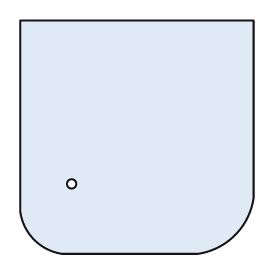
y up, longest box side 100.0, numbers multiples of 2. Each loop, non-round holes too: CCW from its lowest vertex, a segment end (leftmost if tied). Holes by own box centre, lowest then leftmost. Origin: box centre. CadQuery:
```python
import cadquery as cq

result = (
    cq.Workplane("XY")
    .moveTo(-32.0, -50.0)
    .lineTo(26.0, -50.0)
    .threePointArc((42.0, -42.0), (50.0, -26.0))
    .lineTo(50.0, 50.0)
    .lineTo(-50.0, 50.0)
    .lineTo(-50.0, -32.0)
    .threePointArc((-44.0, -44.0), (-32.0, -50.0))
    .close()
    .moveTo(-28.0, -20.0)
    .circle(2.0)
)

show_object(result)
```